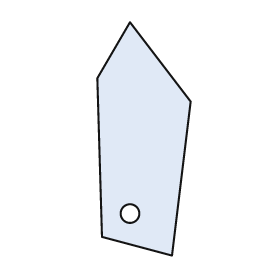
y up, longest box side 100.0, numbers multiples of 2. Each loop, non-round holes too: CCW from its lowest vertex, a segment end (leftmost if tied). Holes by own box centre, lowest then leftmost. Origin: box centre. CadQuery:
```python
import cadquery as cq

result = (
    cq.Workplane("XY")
    .moveTo(12.0, -50.0)
    .lineTo(20.0, 16.0)
    .lineTo(-6.0, 50.0)
    .lineTo(-20.0, 26.0)
    .lineTo(-18.0, -42.0)
    .close()
    .moveTo(-6.0, -32.0)
    .circle(4.0)
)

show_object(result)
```